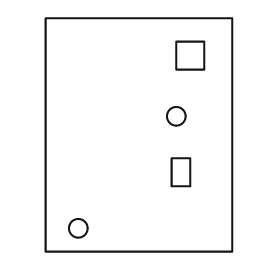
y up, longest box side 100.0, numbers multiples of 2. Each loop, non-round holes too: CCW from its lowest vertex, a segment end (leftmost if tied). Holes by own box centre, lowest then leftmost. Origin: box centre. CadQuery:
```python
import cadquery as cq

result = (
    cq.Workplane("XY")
    .moveTo(-40.0, -50.0)
    .lineTo(40.0, -50.0)
    .lineTo(40.0, 50.0)
    .lineTo(-40.0, 50.0)
    .close()
    .moveTo(-26.0, -40.0)
    .circle(4.0)
    .moveTo(14.0, -22.0)
    .lineTo(22.0, -22.0)
    .lineTo(22.0, -10.0)
    .lineTo(14.0, -10.0)
    .close()
    .moveTo(16.0, 8.0)
    .circle(4.0)
    .moveTo(16.0, 28.0)
    .lineTo(28.0, 28.0)
    .lineTo(28.0, 40.0)
    .lineTo(16.0, 40.0)
    .close()
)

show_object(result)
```